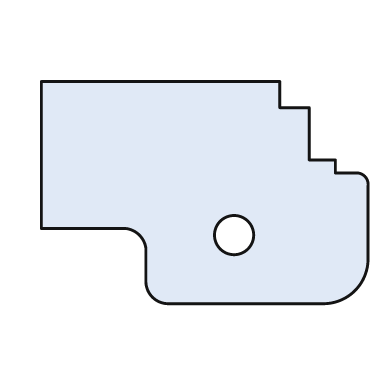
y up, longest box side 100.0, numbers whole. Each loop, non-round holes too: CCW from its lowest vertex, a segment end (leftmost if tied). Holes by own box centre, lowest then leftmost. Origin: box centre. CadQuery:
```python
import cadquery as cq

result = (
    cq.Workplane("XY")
    .moveTo(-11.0, -34.0)
    .lineTo(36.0, -34.0)
    .threePointArc((46.0, -30.0), (50.0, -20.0))
    .lineTo(50.0, 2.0)
    .threePointArc((49.0, 5.0), (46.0, 6.0))
    .lineTo(40.0, 6.0)
    .lineTo(40.0, 10.0)
    .lineTo(32.0, 10.0)
    .lineTo(32.0, 26.0)
    .lineTo(23.0, 26.0)
    .lineTo(23.0, 34.0)
    .lineTo(-50.0, 34.0)
    .lineTo(-50.0, -11.0)
    .lineTo(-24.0, -11.0)
    .threePointArc((-20.0, -13.0), (-18.0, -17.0))
    .lineTo(-18.0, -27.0)
    .threePointArc((-16.0, -32.0), (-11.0, -34.0))
    .close()
    .moveTo(9.0, -13.0)
    .circle(6.0)
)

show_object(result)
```